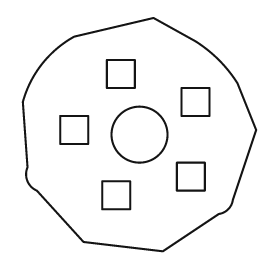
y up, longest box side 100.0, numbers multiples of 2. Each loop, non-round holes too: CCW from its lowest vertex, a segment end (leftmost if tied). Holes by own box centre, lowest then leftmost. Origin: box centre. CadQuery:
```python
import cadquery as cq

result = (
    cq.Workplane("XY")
    .moveTo(10.0, -50.0)
    .lineTo(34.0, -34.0)
    .threePointArc((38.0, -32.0), (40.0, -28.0))
    .lineTo(50.0, 2.0)
    .lineTo(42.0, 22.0)
    .threePointArc((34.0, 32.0), (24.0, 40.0))
    .lineTo(6.0, 50.0)
    .lineTo(-28.0, 42.0)
    .threePointArc((-42.0, 30.0), (-50.0, 14.0))
    .lineTo(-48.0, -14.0)
    .threePointArc((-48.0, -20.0), (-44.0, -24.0))
    .lineTo(-24.0, -46.0)
    .close()
    .moveTo(-16.0, -32.0)
    .lineTo(-4.0, -32.0)
    .lineTo(-4.0, -20.0)
    .lineTo(-16.0, -20.0)
    .close()
    .moveTo(16.0, -24.0)
    .lineTo(28.0, -24.0)
    .lineTo(28.0, -12.0)
    .lineTo(16.0, -12.0)
    .close()
    .moveTo(0.0, 0.0)
    .circle(12.0)
    .moveTo(-34.0, -4.0)
    .lineTo(-22.0, -4.0)
    .lineTo(-22.0, 8.0)
    .lineTo(-34.0, 8.0)
    .close()
    .moveTo(18.0, 8.0)
    .lineTo(30.0, 8.0)
    .lineTo(30.0, 20.0)
    .lineTo(18.0, 20.0)
    .close()
    .moveTo(-14.0, 20.0)
    .lineTo(-2.0, 20.0)
    .lineTo(-2.0, 32.0)
    .lineTo(-14.0, 32.0)
    .close()
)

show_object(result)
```